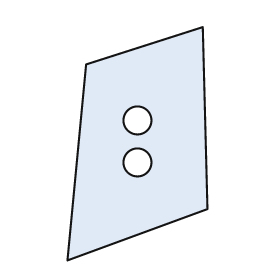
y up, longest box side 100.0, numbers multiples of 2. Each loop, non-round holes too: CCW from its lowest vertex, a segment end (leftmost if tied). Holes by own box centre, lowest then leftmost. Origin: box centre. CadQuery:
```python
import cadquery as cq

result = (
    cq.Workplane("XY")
    .moveTo(-30.0, -50.0)
    .lineTo(30.0, -28.0)
    .lineTo(28.0, 50.0)
    .lineTo(-22.0, 34.0)
    .close()
    .moveTo(0.0, -8.0)
    .circle(6.0)
    .moveTo(0.0, 10.0)
    .circle(6.0)
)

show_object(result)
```